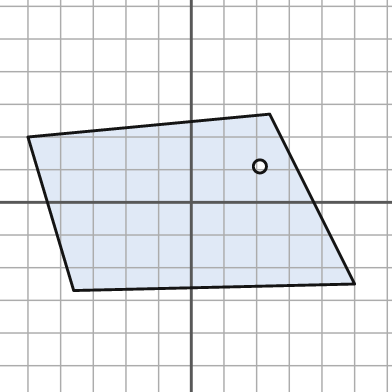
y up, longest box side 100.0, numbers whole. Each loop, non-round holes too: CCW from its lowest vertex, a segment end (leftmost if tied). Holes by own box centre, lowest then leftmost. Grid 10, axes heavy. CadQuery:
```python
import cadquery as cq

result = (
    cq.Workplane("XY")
    .moveTo(-36.0, -27.0)
    .lineTo(50.0, -25.0)
    .lineTo(24.0, 27.0)
    .lineTo(-50.0, 20.0)
    .close()
    .moveTo(21.0, 11.0)
    .circle(2.0)
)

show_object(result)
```